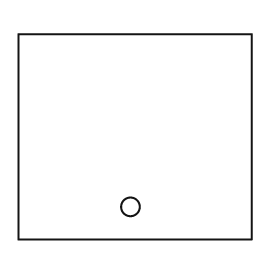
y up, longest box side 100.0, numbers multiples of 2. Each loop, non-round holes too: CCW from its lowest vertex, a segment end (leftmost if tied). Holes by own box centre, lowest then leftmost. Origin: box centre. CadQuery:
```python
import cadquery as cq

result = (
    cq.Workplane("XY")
    .moveTo(-50.0, -44.0)
    .lineTo(50.0, -44.0)
    .lineTo(50.0, 44.0)
    .lineTo(-50.0, 44.0)
    .close()
    .moveTo(-2.0, -30.0)
    .circle(4.0)
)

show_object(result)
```